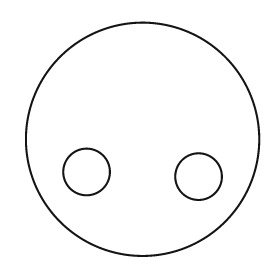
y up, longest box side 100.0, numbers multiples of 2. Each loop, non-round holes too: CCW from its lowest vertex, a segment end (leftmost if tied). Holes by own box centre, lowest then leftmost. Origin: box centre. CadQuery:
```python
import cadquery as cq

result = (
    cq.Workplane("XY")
    .moveTo(0.0, 0.0)
    .circle(50.0)
    .moveTo(24.0, -16.0)
    .circle(10.0)
    .moveTo(-24.0, -14.0)
    .circle(10.0)
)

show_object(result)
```